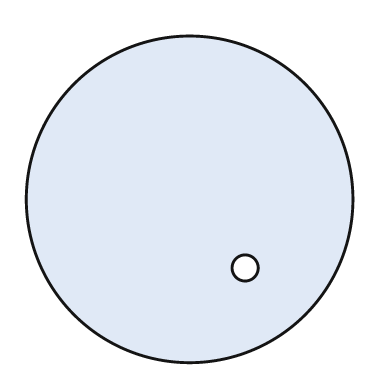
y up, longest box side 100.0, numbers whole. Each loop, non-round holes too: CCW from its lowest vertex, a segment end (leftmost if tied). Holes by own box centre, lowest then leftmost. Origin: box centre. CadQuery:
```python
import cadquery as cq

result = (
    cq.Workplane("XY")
    .moveTo(0.0, 0.0)
    .circle(50.0)
    .moveTo(17.0, -21.0)
    .circle(4.0)
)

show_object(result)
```